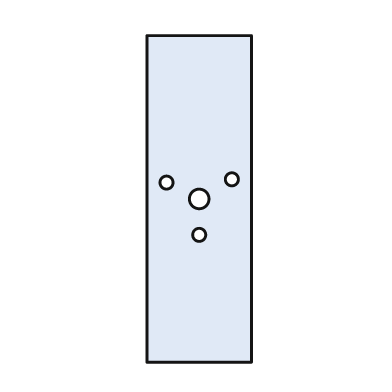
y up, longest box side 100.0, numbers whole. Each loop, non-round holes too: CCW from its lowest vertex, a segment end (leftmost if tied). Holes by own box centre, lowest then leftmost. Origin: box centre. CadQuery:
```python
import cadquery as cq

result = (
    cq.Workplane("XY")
    .moveTo(-16.0, -50.0)
    .lineTo(16.0, -50.0)
    .lineTo(16.0, 50.0)
    .lineTo(-16.0, 50.0)
    .close()
    .moveTo(0.0, -11.0)
    .circle(2.0)
    .moveTo(0.0, 0.0)
    .circle(3.0)
    .moveTo(-10.0, 5.0)
    .circle(2.0)
    .moveTo(10.0, 6.0)
    .circle(2.0)
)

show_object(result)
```